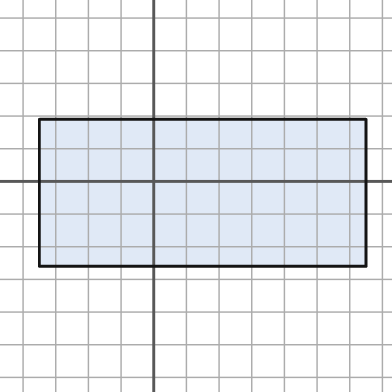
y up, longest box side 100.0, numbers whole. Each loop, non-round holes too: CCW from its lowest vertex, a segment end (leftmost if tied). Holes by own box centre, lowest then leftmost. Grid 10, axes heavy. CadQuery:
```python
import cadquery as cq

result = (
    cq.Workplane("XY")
    .moveTo(-35.0, -26.0)
    .lineTo(65.0, -26.0)
    .lineTo(65.0, 19.0)
    .lineTo(-35.0, 19.0)
    .close()
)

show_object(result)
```